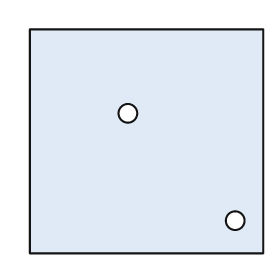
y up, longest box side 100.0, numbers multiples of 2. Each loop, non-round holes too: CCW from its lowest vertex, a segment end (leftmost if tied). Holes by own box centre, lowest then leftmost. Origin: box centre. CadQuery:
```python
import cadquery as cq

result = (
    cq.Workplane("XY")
    .moveTo(-50.0, -48.0)
    .lineTo(50.0, -48.0)
    .lineTo(50.0, 48.0)
    .lineTo(-50.0, 48.0)
    .close()
    .moveTo(38.0, -34.0)
    .circle(4.0)
    .moveTo(-8.0, 12.0)
    .circle(4.0)
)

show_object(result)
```